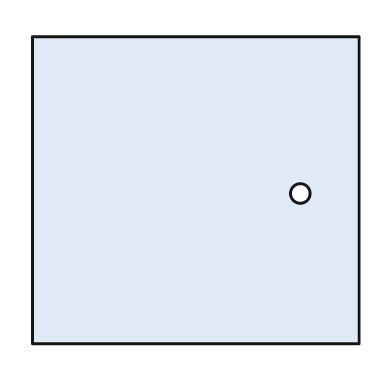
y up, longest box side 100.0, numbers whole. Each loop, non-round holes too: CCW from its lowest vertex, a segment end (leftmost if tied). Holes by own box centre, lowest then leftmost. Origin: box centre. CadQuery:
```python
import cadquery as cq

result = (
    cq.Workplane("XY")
    .moveTo(-50.0, -47.0)
    .lineTo(50.0, -47.0)
    .lineTo(50.0, 47.0)
    .lineTo(-50.0, 47.0)
    .close()
    .moveTo(32.0, -1.0)
    .circle(3.0)
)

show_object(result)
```